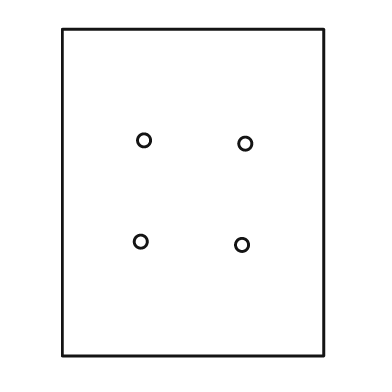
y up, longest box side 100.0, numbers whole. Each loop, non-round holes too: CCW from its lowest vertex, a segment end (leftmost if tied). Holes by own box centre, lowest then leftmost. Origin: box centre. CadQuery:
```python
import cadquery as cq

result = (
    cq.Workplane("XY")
    .moveTo(-40.0, -50.0)
    .lineTo(40.0, -50.0)
    .lineTo(40.0, 50.0)
    .lineTo(-40.0, 50.0)
    .close()
    .moveTo(15.0, -16.0)
    .circle(2.0)
    .moveTo(-16.0, -15.0)
    .circle(2.0)
    .moveTo(16.0, 15.0)
    .circle(2.0)
    .moveTo(-15.0, 16.0)
    .circle(2.0)
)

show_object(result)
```